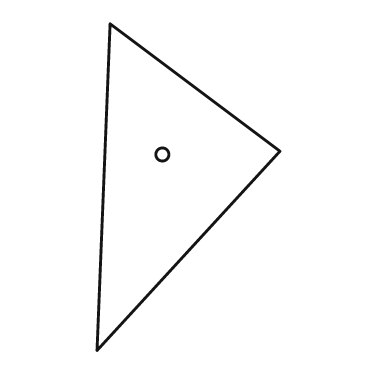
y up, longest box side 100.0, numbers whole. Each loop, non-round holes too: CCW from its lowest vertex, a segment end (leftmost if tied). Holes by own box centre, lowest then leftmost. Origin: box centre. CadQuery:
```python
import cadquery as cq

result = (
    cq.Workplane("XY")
    .moveTo(-28.0, -50.0)
    .lineTo(28.0, 11.0)
    .lineTo(-24.0, 50.0)
    .close()
    .moveTo(-8.0, 10.0)
    .circle(2.0)
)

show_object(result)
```